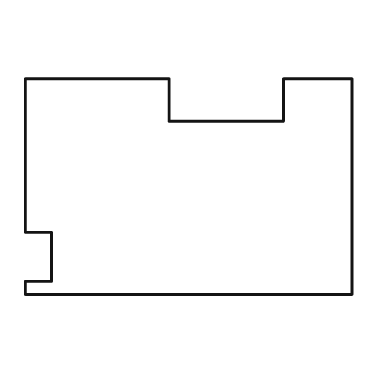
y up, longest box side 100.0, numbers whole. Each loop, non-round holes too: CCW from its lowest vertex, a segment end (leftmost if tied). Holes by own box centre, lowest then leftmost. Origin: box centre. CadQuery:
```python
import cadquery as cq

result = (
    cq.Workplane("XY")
    .moveTo(-50.0, -33.0)
    .lineTo(50.0, -33.0)
    .lineTo(50.0, 33.0)
    .lineTo(29.0, 33.0)
    .lineTo(29.0, 20.0)
    .lineTo(-6.0, 20.0)
    .lineTo(-6.0, 33.0)
    .lineTo(-50.0, 33.0)
    .lineTo(-50.0, -14.0)
    .lineTo(-42.0, -14.0)
    .lineTo(-42.0, -29.0)
    .lineTo(-50.0, -29.0)
    .close()
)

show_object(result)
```